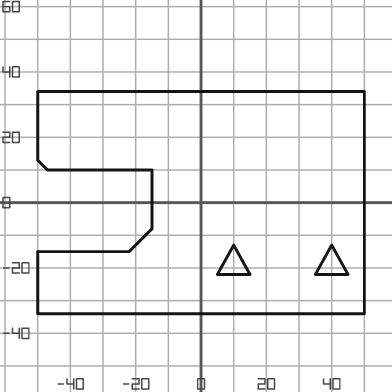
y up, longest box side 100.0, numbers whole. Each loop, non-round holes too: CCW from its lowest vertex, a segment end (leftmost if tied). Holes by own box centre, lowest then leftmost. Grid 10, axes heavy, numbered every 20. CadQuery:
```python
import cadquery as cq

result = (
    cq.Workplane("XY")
    .moveTo(-50.0, -34.0)
    .lineTo(50.0, -34.0)
    .lineTo(50.0, 34.0)
    .lineTo(-50.0, 34.0)
    .lineTo(-50.0, 13.0)
    .lineTo(-47.0, 10.0)
    .lineTo(-15.0, 10.0)
    .lineTo(-15.0, -8.0)
    .lineTo(-22.0, -15.0)
    .lineTo(-50.0, -15.0)
    .close()
    .moveTo(5.0, -22.0)
    .lineTo(15.0, -22.0)
    .lineTo(10.0, -13.0)
    .close()
    .moveTo(35.0, -22.0)
    .lineTo(45.0, -22.0)
    .lineTo(40.0, -13.0)
    .close()
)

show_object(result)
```